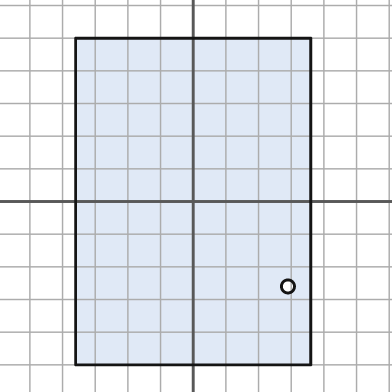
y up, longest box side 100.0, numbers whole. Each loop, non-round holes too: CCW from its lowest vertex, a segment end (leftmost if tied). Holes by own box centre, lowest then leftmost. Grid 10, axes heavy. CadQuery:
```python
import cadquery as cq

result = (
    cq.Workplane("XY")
    .moveTo(-36.0, -50.0)
    .lineTo(36.0, -50.0)
    .lineTo(36.0, 50.0)
    .lineTo(-36.0, 50.0)
    .close()
    .moveTo(29.0, -26.0)
    .circle(2.0)
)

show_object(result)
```